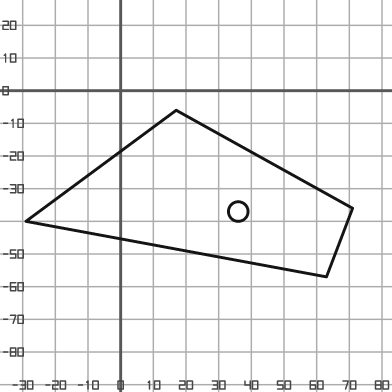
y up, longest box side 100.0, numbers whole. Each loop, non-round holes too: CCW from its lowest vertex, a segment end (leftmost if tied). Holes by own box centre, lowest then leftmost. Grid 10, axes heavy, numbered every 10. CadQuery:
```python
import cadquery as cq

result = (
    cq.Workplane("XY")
    .moveTo(63.0, -57.0)
    .lineTo(71.0, -36.0)
    .lineTo(17.0, -6.0)
    .lineTo(-29.0, -40.0)
    .close()
    .moveTo(36.0, -37.0)
    .circle(3.0)
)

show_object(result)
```